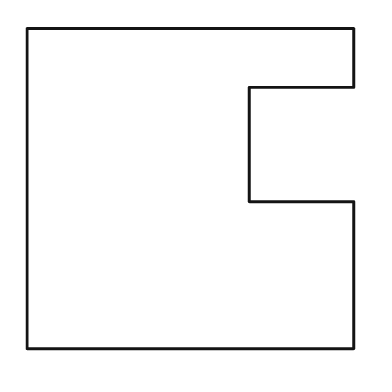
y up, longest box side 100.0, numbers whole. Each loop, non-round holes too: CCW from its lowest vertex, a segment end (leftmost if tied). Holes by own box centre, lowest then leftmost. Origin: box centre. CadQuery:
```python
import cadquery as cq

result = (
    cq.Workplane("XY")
    .moveTo(-50.0, -49.0)
    .lineTo(50.0, -49.0)
    .lineTo(50.0, -4.0)
    .lineTo(18.0, -4.0)
    .lineTo(18.0, 31.0)
    .lineTo(50.0, 31.0)
    .lineTo(50.0, 49.0)
    .lineTo(-50.0, 49.0)
    .close()
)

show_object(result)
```